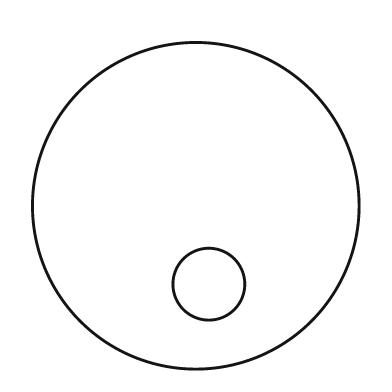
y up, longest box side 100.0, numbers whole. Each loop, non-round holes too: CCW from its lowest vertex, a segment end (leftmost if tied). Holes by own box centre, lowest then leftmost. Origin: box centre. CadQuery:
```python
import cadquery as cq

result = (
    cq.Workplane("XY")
    .moveTo(0.0, 0.0)
    .circle(50.0)
    .moveTo(4.0, -24.0)
    .circle(11.0)
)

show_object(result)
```